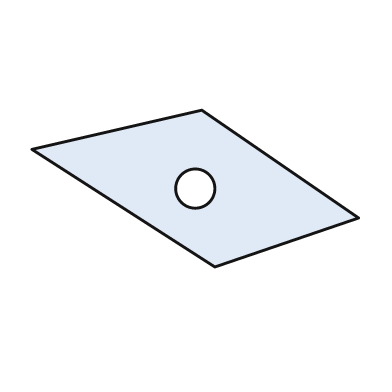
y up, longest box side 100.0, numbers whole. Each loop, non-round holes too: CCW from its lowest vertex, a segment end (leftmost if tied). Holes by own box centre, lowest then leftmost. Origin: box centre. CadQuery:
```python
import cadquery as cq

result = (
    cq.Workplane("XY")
    .moveTo(6.0, -24.0)
    .lineTo(50.0, -9.0)
    .lineTo(2.0, 24.0)
    .lineTo(-50.0, 12.0)
    .close()
    .moveTo(0.0, 0.0)
    .circle(6.0)
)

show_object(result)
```